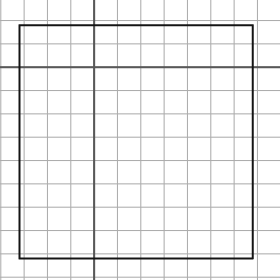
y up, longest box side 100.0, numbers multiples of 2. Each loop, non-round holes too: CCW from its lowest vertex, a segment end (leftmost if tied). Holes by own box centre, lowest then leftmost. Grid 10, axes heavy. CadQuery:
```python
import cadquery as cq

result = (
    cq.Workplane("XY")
    .moveTo(-32.0, -82.0)
    .lineTo(68.0, -82.0)
    .lineTo(68.0, 18.0)
    .lineTo(-32.0, 18.0)
    .close()
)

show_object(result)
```